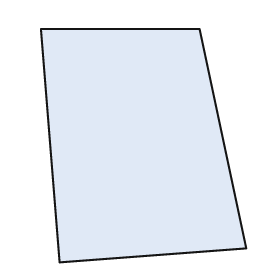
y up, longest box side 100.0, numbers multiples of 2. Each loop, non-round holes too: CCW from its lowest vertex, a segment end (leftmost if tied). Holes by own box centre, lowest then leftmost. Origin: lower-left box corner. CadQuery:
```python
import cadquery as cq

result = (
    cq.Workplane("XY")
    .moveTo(8.0, 0.0)
    .lineTo(88.0, 6.0)
    .lineTo(68.0, 100.0)
    .lineTo(0.0, 100.0)
    .close()
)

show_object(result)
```